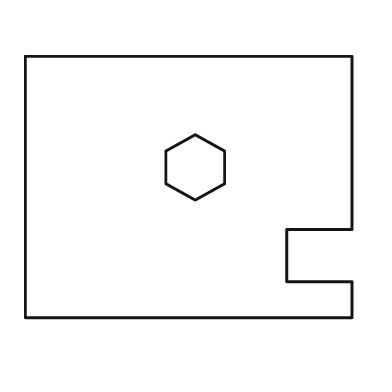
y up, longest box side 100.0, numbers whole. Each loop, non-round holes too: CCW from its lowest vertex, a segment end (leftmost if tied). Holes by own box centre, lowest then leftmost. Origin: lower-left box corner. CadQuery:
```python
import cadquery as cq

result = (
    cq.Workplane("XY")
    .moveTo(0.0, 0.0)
    .lineTo(100.0, 0.0)
    .lineTo(100.0, 11.0)
    .lineTo(80.0, 11.0)
    .lineTo(80.0, 27.0)
    .lineTo(100.0, 27.0)
    .lineTo(100.0, 80.0)
    .lineTo(0.0, 80.0)
    .close()
    .moveTo(52.0, 36.0)
    .lineTo(61.0, 41.0)
    .lineTo(61.0, 51.0)
    .lineTo(52.0, 56.0)
    .lineTo(43.0, 51.0)
    .lineTo(43.0, 41.0)
    .close()
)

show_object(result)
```